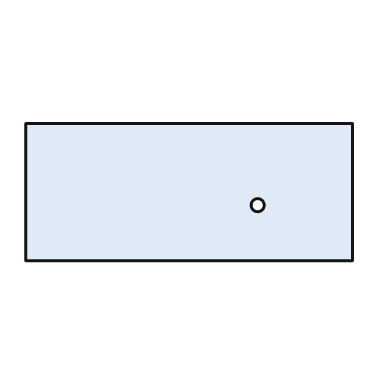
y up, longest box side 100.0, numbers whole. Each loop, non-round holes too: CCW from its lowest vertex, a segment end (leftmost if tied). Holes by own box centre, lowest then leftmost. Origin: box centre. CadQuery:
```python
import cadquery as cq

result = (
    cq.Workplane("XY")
    .moveTo(-50.0, -21.0)
    .lineTo(50.0, -21.0)
    .lineTo(50.0, 21.0)
    .lineTo(-50.0, 21.0)
    .close()
    .moveTo(21.0, -4.0)
    .circle(2.0)
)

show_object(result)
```